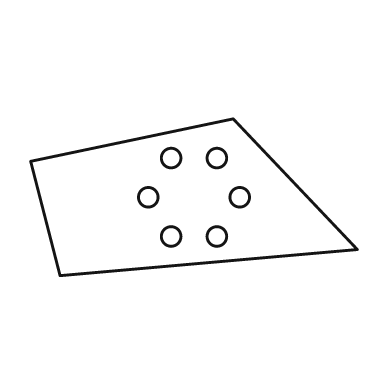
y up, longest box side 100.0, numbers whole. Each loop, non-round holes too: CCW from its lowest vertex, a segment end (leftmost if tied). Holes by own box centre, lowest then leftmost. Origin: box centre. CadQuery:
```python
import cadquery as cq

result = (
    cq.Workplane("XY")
    .moveTo(-41.0, -24.0)
    .lineTo(50.0, -16.0)
    .lineTo(12.0, 24.0)
    .lineTo(-50.0, 11.0)
    .close()
    .moveTo(-7.0, -12.0)
    .circle(3.0)
    .moveTo(7.0, -12.0)
    .circle(3.0)
    .moveTo(-14.0, 0.0)
    .circle(3.0)
    .moveTo(14.0, 0.0)
    .circle(3.0)
    .moveTo(-7.0, 12.0)
    .circle(3.0)
    .moveTo(7.0, 12.0)
    .circle(3.0)
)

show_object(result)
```